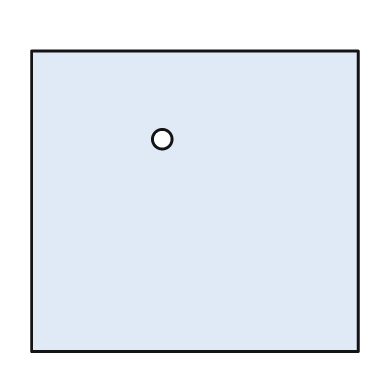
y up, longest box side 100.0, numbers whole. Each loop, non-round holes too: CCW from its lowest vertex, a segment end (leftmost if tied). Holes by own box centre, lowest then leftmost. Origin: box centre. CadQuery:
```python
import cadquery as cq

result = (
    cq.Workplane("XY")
    .moveTo(-50.0, -46.0)
    .lineTo(50.0, -46.0)
    .lineTo(50.0, 46.0)
    .lineTo(-50.0, 46.0)
    .close()
    .moveTo(-10.0, 19.0)
    .circle(3.0)
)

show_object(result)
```